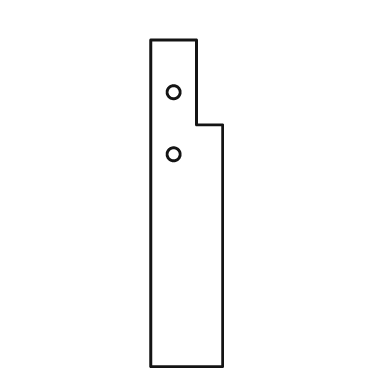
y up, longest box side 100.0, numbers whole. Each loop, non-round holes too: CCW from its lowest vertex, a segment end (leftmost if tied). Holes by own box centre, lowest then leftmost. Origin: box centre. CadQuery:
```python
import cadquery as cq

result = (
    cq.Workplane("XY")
    .moveTo(-11.0, -50.0)
    .lineTo(11.0, -50.0)
    .lineTo(11.0, 24.0)
    .lineTo(3.0, 24.0)
    .lineTo(3.0, 50.0)
    .lineTo(-11.0, 50.0)
    .close()
    .moveTo(-4.0, 15.0)
    .circle(2.0)
    .moveTo(-4.0, 34.0)
    .circle(2.0)
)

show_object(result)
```